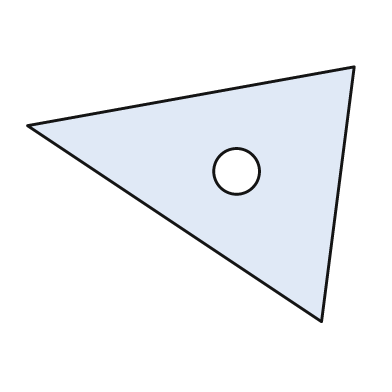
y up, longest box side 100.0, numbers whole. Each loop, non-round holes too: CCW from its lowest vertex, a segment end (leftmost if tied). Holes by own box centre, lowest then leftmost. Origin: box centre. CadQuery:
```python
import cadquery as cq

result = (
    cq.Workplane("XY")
    .moveTo(40.0, -39.0)
    .lineTo(50.0, 39.0)
    .lineTo(-50.0, 21.0)
    .close()
    .moveTo(14.0, 7.0)
    .circle(7.0)
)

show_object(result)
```